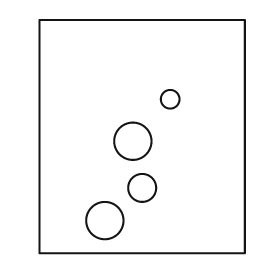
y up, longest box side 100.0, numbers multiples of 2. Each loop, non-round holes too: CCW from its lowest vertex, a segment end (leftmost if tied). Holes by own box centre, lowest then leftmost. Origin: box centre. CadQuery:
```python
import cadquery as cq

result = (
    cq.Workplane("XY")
    .moveTo(-44.0, -50.0)
    .lineTo(44.0, -50.0)
    .lineTo(44.0, 50.0)
    .lineTo(-44.0, 50.0)
    .close()
    .moveTo(-16.0, -36.0)
    .circle(8.0)
    .moveTo(0.0, -22.0)
    .circle(6.0)
    .moveTo(-4.0, -2.0)
    .circle(8.0)
    .moveTo(12.0, 16.0)
    .circle(4.0)
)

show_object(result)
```